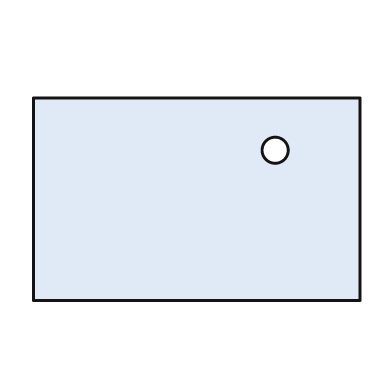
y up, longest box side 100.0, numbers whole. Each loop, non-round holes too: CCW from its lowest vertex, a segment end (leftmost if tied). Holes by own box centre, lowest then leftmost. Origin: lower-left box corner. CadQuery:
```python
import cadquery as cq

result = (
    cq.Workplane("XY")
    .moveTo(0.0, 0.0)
    .lineTo(100.0, 0.0)
    .lineTo(100.0, 62.0)
    .lineTo(0.0, 62.0)
    .close()
    .moveTo(74.0, 46.0)
    .circle(4.0)
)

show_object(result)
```